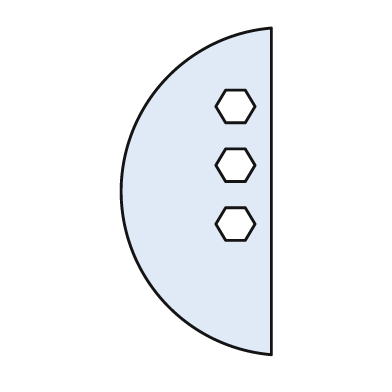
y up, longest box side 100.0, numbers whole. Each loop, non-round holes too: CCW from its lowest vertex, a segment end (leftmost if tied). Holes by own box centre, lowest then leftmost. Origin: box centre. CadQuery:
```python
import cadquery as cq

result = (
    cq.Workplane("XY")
    .moveTo(23.0, -50.0)
    .lineTo(23.0, 50.0)
    .threePointArc((-23.0, 0.0), (23.0, -50.0))
    .close()
    .moveTo(9.0, -15.0)
    .lineTo(15.0, -15.0)
    .lineTo(18.0, -10.0)
    .lineTo(15.0, -5.0)
    .lineTo(9.0, -5.0)
    .lineTo(6.0, -10.0)
    .close()
    .moveTo(9.0, 3.0)
    .lineTo(15.0, 3.0)
    .lineTo(18.0, 8.0)
    .lineTo(15.0, 13.0)
    .lineTo(9.0, 13.0)
    .lineTo(6.0, 8.0)
    .close()
    .moveTo(9.0, 21.0)
    .lineTo(15.0, 21.0)
    .lineTo(18.0, 26.0)
    .lineTo(15.0, 31.0)
    .lineTo(9.0, 31.0)
    .lineTo(6.0, 26.0)
    .close()
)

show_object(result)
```